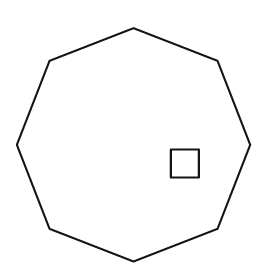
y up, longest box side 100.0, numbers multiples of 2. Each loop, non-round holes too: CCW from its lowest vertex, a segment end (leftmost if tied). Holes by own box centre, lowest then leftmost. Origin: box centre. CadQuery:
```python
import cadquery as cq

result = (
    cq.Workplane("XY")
    .moveTo(0.0, -50.0)
    .lineTo(36.0, -36.0)
    .lineTo(50.0, 0.0)
    .lineTo(36.0, 36.0)
    .lineTo(0.0, 50.0)
    .lineTo(-36.0, 36.0)
    .lineTo(-50.0, 0.0)
    .lineTo(-36.0, -36.0)
    .close()
    .moveTo(16.0, -14.0)
    .lineTo(28.0, -14.0)
    .lineTo(28.0, -2.0)
    .lineTo(16.0, -2.0)
    .close()
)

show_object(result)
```